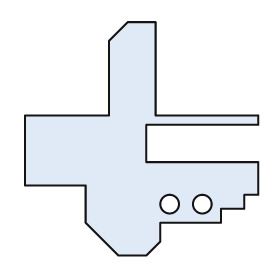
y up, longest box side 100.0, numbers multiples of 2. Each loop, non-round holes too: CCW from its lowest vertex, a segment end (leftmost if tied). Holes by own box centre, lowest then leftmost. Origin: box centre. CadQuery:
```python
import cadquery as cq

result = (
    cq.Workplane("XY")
    .moveTo(-10.0, -50.0)
    .lineTo(2.0, -50.0)
    .lineTo(8.0, -44.0)
    .lineTo(8.0, -36.0)
    .lineTo(34.0, -36.0)
    .lineTo(34.0, -30.0)
    .lineTo(44.0, -30.0)
    .lineTo(44.0, -24.0)
    .lineTo(50.0, -24.0)
    .lineTo(50.0, -10.0)
    .lineTo(2.0, -10.0)
    .lineTo(2.0, 6.0)
    .lineTo(50.0, 6.0)
    .lineTo(50.0, 10.0)
    .lineTo(6.0, 10.0)
    .lineTo(6.0, 50.0)
    .lineTo(-6.0, 50.0)
    .lineTo(-14.0, 42.0)
    .lineTo(-14.0, 10.0)
    .lineTo(-50.0, 10.0)
    .lineTo(-50.0, -20.0)
    .lineTo(-24.0, -20.0)
    .lineTo(-24.0, -36.0)
    .close()
    .moveTo(12.0, -28.0)
    .circle(4.0)
    .moveTo(26.0, -28.0)
    .circle(4.0)
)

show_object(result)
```